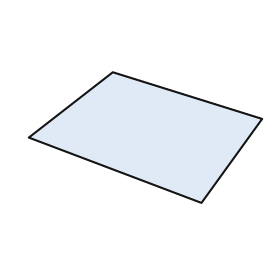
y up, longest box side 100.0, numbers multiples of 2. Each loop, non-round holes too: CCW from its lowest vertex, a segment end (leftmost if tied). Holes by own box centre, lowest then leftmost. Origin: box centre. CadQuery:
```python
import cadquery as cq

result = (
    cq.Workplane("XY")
    .moveTo(24.0, -28.0)
    .lineTo(50.0, 8.0)
    .lineTo(-14.0, 28.0)
    .lineTo(-50.0, 0.0)
    .close()
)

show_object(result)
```